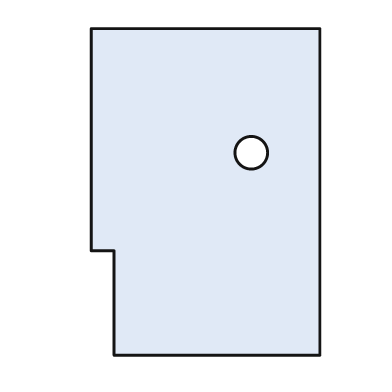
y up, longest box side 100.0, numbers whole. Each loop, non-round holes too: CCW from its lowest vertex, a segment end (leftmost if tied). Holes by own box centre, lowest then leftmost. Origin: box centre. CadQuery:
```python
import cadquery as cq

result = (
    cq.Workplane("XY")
    .moveTo(-28.0, -50.0)
    .lineTo(35.0, -50.0)
    .lineTo(35.0, 50.0)
    .lineTo(-35.0, 50.0)
    .lineTo(-35.0, -18.0)
    .lineTo(-28.0, -18.0)
    .close()
    .moveTo(14.0, 12.0)
    .circle(5.0)
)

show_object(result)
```